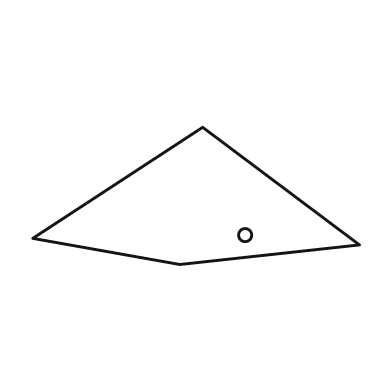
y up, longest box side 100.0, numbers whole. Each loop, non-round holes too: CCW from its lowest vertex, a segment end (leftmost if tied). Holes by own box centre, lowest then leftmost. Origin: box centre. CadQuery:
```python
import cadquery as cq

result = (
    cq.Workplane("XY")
    .moveTo(-5.0, -21.0)
    .lineTo(50.0, -15.0)
    .lineTo(2.0, 21.0)
    .lineTo(-50.0, -13.0)
    .close()
    .moveTo(15.0, -12.0)
    .circle(2.0)
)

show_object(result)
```